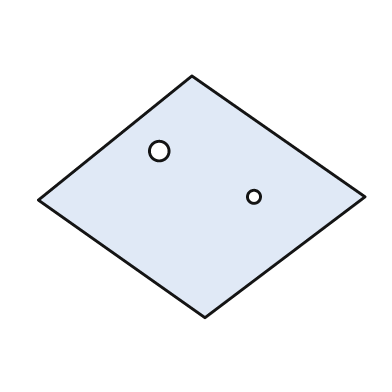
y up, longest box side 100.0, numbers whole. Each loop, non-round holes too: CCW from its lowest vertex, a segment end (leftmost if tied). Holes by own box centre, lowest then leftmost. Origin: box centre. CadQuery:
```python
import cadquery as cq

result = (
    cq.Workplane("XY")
    .moveTo(1.0, -37.0)
    .lineTo(50.0, 0.0)
    .lineTo(-3.0, 37.0)
    .lineTo(-50.0, -1.0)
    .close()
    .moveTo(16.0, 0.0)
    .circle(2.0)
    .moveTo(-13.0, 14.0)
    .circle(3.0)
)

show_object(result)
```